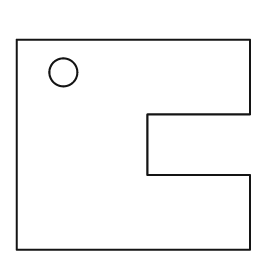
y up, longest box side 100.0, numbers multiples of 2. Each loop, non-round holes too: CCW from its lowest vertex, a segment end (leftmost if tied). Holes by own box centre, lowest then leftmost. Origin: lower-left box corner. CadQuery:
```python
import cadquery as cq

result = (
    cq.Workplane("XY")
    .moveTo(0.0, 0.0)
    .lineTo(100.0, 0.0)
    .lineTo(100.0, 32.0)
    .lineTo(56.0, 32.0)
    .lineTo(56.0, 58.0)
    .lineTo(100.0, 58.0)
    .lineTo(100.0, 90.0)
    .lineTo(0.0, 90.0)
    .close()
    .moveTo(20.0, 76.0)
    .circle(6.0)
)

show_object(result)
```